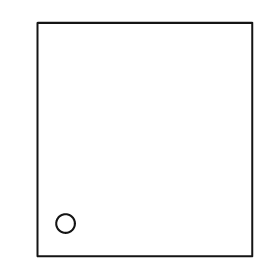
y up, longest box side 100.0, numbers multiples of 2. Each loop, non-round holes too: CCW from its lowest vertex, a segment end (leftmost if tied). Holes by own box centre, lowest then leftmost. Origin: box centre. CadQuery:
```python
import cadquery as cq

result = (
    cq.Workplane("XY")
    .moveTo(-46.0, -50.0)
    .lineTo(46.0, -50.0)
    .lineTo(46.0, 50.0)
    .lineTo(-46.0, 50.0)
    .close()
    .moveTo(-34.0, -36.0)
    .circle(4.0)
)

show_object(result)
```